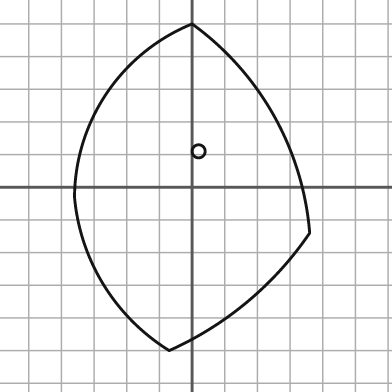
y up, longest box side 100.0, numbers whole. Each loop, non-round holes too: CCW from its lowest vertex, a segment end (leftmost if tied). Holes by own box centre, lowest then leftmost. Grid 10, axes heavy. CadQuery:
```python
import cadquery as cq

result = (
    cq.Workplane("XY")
    .moveTo(-7.0, -50.0)
    .threePointArc((17.0, -35.0), (36.0, -14.0))
    .threePointArc((25.0, 22.0), (0.0, 50.0))
    .threePointArc((-26.0, 29.0), (-36.0, -3.0))
    .threePointArc((-27.0, -30.0), (-7.0, -50.0))
    .close()
    .moveTo(2.0, 11.0)
    .circle(2.0)
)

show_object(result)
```